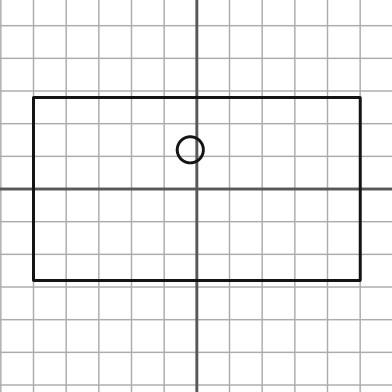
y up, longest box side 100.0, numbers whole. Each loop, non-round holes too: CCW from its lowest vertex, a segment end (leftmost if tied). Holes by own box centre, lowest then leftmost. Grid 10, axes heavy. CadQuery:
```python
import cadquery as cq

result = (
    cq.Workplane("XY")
    .moveTo(-50.0, -28.0)
    .lineTo(50.0, -28.0)
    .lineTo(50.0, 28.0)
    .lineTo(-50.0, 28.0)
    .close()
    .moveTo(-2.0, 12.0)
    .circle(4.0)
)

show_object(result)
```